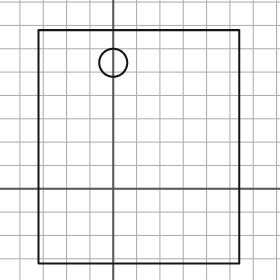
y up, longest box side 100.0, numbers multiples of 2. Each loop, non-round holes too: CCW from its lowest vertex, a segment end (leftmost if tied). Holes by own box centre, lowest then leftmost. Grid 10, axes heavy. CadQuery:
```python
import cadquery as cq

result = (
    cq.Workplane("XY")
    .moveTo(-32.0, -32.0)
    .lineTo(54.0, -32.0)
    .lineTo(54.0, 68.0)
    .lineTo(-32.0, 68.0)
    .close()
    .moveTo(0.0, 54.0)
    .circle(6.0)
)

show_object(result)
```